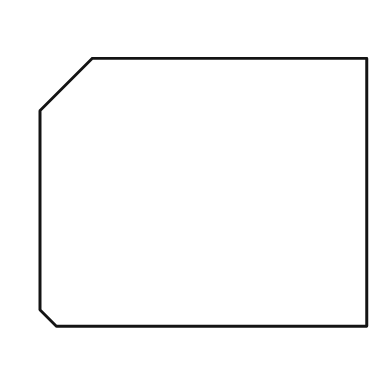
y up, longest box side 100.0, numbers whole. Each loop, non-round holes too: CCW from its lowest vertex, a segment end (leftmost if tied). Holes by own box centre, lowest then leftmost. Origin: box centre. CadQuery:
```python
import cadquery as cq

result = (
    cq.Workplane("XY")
    .moveTo(-45.0, -41.0)
    .lineTo(50.0, -41.0)
    .lineTo(50.0, 41.0)
    .lineTo(-34.0, 41.0)
    .lineTo(-50.0, 25.0)
    .lineTo(-50.0, -36.0)
    .close()
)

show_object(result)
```